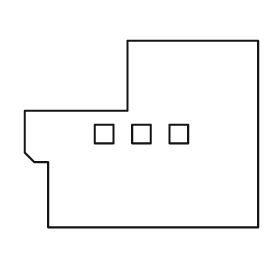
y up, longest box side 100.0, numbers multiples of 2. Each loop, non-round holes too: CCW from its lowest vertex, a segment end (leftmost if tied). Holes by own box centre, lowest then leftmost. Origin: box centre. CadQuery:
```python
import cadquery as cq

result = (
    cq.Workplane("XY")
    .moveTo(-40.0, -40.0)
    .lineTo(50.0, -40.0)
    .lineTo(50.0, 40.0)
    .lineTo(-6.0, 40.0)
    .lineTo(-6.0, 10.0)
    .lineTo(-50.0, 10.0)
    .lineTo(-50.0, -8.0)
    .lineTo(-46.0, -12.0)
    .lineTo(-40.0, -12.0)
    .close()
    .moveTo(-20.0, -4.0)
    .lineTo(-12.0, -4.0)
    .lineTo(-12.0, 4.0)
    .lineTo(-20.0, 4.0)
    .close()
    .moveTo(-4.0, -4.0)
    .lineTo(4.0, -4.0)
    .lineTo(4.0, 4.0)
    .lineTo(-4.0, 4.0)
    .close()
    .moveTo(12.0, -4.0)
    .lineTo(20.0, -4.0)
    .lineTo(20.0, 4.0)
    .lineTo(12.0, 4.0)
    .close()
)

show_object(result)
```